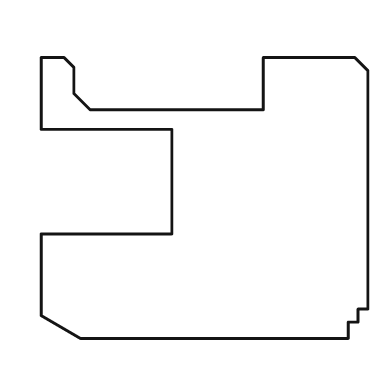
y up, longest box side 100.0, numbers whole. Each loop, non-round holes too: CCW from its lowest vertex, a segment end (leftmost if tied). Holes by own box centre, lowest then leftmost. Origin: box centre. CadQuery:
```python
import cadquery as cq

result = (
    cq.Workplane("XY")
    .moveTo(-38.0, -43.0)
    .lineTo(44.0, -43.0)
    .lineTo(44.0, -38.0)
    .lineTo(47.0, -38.0)
    .lineTo(47.0, -34.0)
    .lineTo(50.0, -34.0)
    .lineTo(50.0, 39.0)
    .lineTo(46.0, 43.0)
    .lineTo(18.0, 43.0)
    .lineTo(18.0, 27.0)
    .lineTo(-35.0, 27.0)
    .lineTo(-40.0, 32.0)
    .lineTo(-40.0, 40.0)
    .lineTo(-43.0, 43.0)
    .lineTo(-50.0, 43.0)
    .lineTo(-50.0, 21.0)
    .lineTo(-10.0, 21.0)
    .lineTo(-10.0, -11.0)
    .lineTo(-50.0, -11.0)
    .lineTo(-50.0, -36.0)
    .close()
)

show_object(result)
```